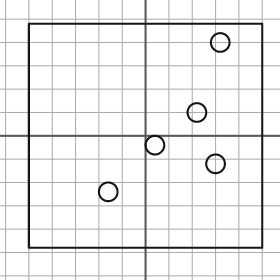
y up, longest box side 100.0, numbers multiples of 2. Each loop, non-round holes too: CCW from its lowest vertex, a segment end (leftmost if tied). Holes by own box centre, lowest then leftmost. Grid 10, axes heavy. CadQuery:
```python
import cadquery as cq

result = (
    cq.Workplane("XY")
    .moveTo(-50.0, -48.0)
    .lineTo(50.0, -48.0)
    .lineTo(50.0, 48.0)
    .lineTo(-50.0, 48.0)
    .close()
    .moveTo(-16.0, -24.0)
    .circle(4.0)
    .moveTo(30.0, -12.0)
    .circle(4.0)
    .moveTo(4.0, -4.0)
    .circle(4.0)
    .moveTo(22.0, 10.0)
    .circle(4.0)
    .moveTo(32.0, 40.0)
    .circle(4.0)
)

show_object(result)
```